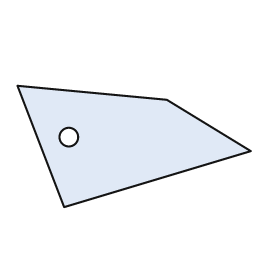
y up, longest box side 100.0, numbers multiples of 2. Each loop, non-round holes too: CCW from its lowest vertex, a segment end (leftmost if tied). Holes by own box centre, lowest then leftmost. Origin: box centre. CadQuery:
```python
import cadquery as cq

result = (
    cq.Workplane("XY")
    .moveTo(-30.0, -26.0)
    .lineTo(50.0, -2.0)
    .lineTo(14.0, 20.0)
    .lineTo(-50.0, 26.0)
    .close()
    .moveTo(-28.0, 4.0)
    .circle(4.0)
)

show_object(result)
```